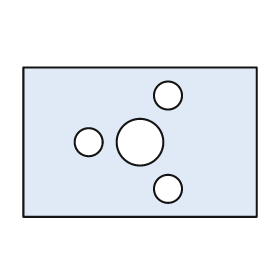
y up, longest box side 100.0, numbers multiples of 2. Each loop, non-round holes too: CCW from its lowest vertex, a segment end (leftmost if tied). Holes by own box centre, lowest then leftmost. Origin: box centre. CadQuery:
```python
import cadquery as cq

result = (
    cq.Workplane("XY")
    .moveTo(-50.0, -32.0)
    .lineTo(50.0, -32.0)
    .lineTo(50.0, 32.0)
    .lineTo(-50.0, 32.0)
    .close()
    .moveTo(12.0, -20.0)
    .circle(6.0)
    .moveTo(-22.0, 0.0)
    .circle(6.0)
    .moveTo(0.0, 0.0)
    .circle(10.0)
    .moveTo(12.0, 20.0)
    .circle(6.0)
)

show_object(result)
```